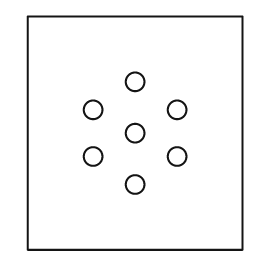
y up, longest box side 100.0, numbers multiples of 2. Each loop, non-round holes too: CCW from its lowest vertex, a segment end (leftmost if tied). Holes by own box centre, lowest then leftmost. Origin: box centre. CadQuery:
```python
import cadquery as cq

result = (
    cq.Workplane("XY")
    .moveTo(-46.0, -50.0)
    .lineTo(46.0, -50.0)
    .lineTo(46.0, 50.0)
    .lineTo(-46.0, 50.0)
    .close()
    .moveTo(0.0, -22.0)
    .circle(4.0)
    .moveTo(-18.0, -10.0)
    .circle(4.0)
    .moveTo(18.0, -10.0)
    .circle(4.0)
    .moveTo(0.0, 0.0)
    .circle(4.0)
    .moveTo(-18.0, 10.0)
    .circle(4.0)
    .moveTo(18.0, 10.0)
    .circle(4.0)
    .moveTo(0.0, 22.0)
    .circle(4.0)
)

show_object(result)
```